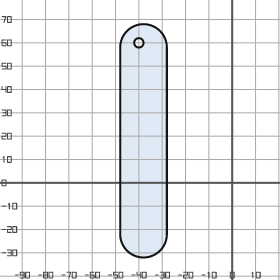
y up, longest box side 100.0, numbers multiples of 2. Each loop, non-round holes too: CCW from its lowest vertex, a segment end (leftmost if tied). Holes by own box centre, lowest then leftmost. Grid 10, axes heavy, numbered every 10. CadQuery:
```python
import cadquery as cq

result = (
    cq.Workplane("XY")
    .moveTo(-48.0, -22.0)
    .threePointArc((-38.0, -32.0), (-28.0, -22.0))
    .lineTo(-28.0, 58.0)
    .threePointArc((-38.0, 68.0), (-48.0, 58.0))
    .close()
    .moveTo(-40.0, 60.0)
    .circle(2.0)
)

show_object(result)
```